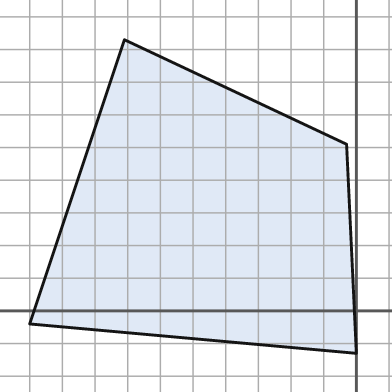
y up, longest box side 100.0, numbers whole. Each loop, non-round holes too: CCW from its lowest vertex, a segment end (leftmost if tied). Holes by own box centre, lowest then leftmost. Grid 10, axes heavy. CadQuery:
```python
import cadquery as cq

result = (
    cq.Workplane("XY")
    .moveTo(0.0, -13.0)
    .lineTo(-3.0, 51.0)
    .lineTo(-71.0, 83.0)
    .lineTo(-100.0, -4.0)
    .close()
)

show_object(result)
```